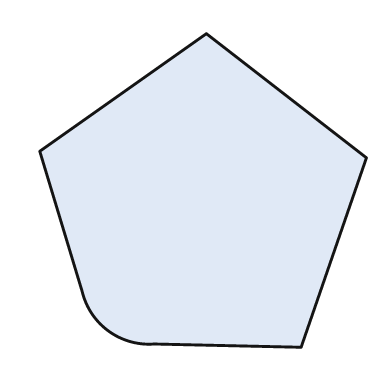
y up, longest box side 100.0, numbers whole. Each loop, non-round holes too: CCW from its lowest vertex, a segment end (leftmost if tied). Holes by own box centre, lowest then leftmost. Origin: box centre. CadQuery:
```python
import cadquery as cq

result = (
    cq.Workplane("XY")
    .moveTo(30.0, -48.0)
    .lineTo(50.0, 10.0)
    .lineTo(1.0, 48.0)
    .lineTo(-50.0, 12.0)
    .lineTo(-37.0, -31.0)
    .threePointArc((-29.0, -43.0), (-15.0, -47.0))
    .close()
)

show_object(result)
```